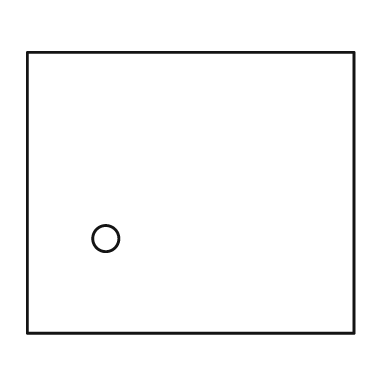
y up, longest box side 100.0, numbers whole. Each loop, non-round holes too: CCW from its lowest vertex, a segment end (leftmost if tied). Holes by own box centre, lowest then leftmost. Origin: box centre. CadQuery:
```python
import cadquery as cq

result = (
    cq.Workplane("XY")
    .moveTo(-50.0, -43.0)
    .lineTo(50.0, -43.0)
    .lineTo(50.0, 43.0)
    .lineTo(-50.0, 43.0)
    .close()
    .moveTo(-26.0, -14.0)
    .circle(4.0)
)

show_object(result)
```